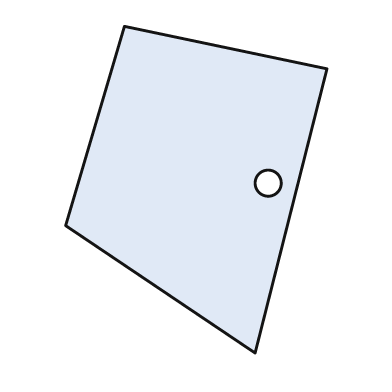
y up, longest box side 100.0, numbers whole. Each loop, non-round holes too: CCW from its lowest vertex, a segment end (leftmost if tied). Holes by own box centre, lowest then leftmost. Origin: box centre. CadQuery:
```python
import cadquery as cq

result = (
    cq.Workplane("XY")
    .moveTo(18.0, -50.0)
    .lineTo(40.0, 37.0)
    .lineTo(-22.0, 50.0)
    .lineTo(-40.0, -11.0)
    .close()
    .moveTo(22.0, 2.0)
    .circle(4.0)
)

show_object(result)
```